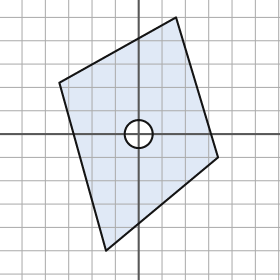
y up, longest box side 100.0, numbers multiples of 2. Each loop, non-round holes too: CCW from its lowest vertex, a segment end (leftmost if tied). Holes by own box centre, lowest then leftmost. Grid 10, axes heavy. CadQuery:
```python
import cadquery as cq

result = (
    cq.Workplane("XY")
    .moveTo(-14.0, -50.0)
    .lineTo(34.0, -10.0)
    .lineTo(16.0, 50.0)
    .lineTo(-34.0, 22.0)
    .close()
    .moveTo(0.0, 0.0)
    .circle(6.0)
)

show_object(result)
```